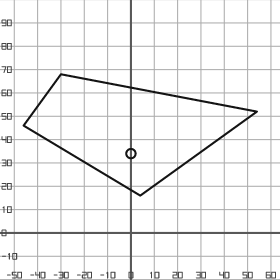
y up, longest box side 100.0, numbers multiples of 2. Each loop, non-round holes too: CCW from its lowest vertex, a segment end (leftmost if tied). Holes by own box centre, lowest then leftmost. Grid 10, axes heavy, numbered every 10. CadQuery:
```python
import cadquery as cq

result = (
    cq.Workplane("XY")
    .moveTo(4.0, 16.0)
    .lineTo(54.0, 52.0)
    .lineTo(-30.0, 68.0)
    .lineTo(-46.0, 46.0)
    .close()
    .moveTo(0.0, 34.0)
    .circle(2.0)
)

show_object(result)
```